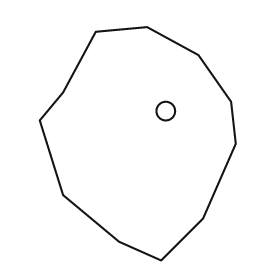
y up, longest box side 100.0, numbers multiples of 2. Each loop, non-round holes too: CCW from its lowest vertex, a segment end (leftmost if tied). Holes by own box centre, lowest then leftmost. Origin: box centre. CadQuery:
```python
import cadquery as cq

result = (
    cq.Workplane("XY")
    .moveTo(10.0, -50.0)
    .lineTo(28.0, -32.0)
    .lineTo(42.0, 0.0)
    .lineTo(40.0, 18.0)
    .lineTo(26.0, 38.0)
    .lineTo(4.0, 50.0)
    .lineTo(-18.0, 48.0)
    .lineTo(-32.0, 22.0)
    .lineTo(-42.0, 10.0)
    .lineTo(-32.0, -22.0)
    .lineTo(-8.0, -42.0)
    .close()
    .moveTo(12.0, 14.0)
    .circle(4.0)
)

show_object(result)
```